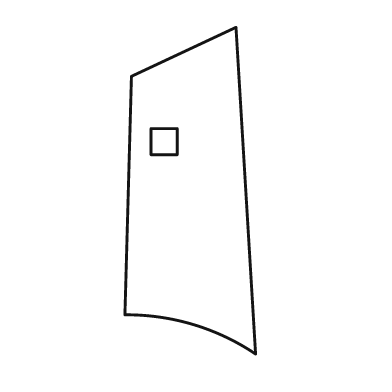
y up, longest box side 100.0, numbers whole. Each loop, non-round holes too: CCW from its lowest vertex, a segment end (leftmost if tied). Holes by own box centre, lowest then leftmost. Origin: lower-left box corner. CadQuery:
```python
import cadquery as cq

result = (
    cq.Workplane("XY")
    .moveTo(40.0, 0.0)
    .lineTo(34.0, 100.0)
    .lineTo(2.0, 85.0)
    .lineTo(0.0, 12.0)
    .threePointArc((21.0, 9.0), (40.0, 0.0))
    .close()
    .moveTo(8.0, 61.0)
    .lineTo(16.0, 61.0)
    .lineTo(16.0, 69.0)
    .lineTo(8.0, 69.0)
    .close()
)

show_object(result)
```